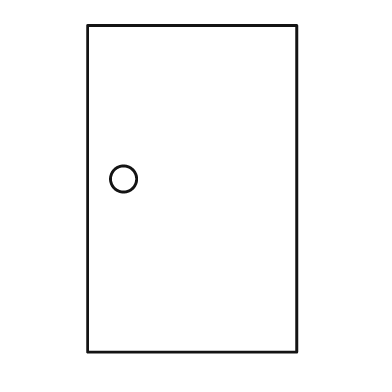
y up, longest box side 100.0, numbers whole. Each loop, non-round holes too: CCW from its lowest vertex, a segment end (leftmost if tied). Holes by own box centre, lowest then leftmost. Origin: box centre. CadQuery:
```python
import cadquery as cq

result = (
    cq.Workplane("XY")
    .moveTo(-32.0, -50.0)
    .lineTo(32.0, -50.0)
    .lineTo(32.0, 50.0)
    .lineTo(-32.0, 50.0)
    .close()
    .moveTo(-21.0, 3.0)
    .circle(4.0)
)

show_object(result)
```